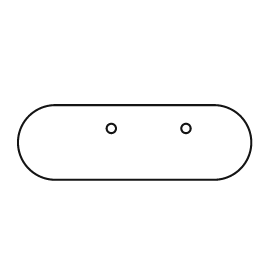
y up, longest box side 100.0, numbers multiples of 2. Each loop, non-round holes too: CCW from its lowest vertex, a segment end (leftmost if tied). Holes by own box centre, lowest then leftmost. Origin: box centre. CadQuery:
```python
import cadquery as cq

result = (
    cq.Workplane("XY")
    .moveTo(-34.0, -16.0)
    .lineTo(34.0, -16.0)
    .threePointArc((50.0, 0.0), (34.0, 16.0))
    .lineTo(-34.0, 16.0)
    .threePointArc((-50.0, 0.0), (-34.0, -16.0))
    .close()
    .moveTo(-10.0, 6.0)
    .circle(2.0)
    .moveTo(22.0, 6.0)
    .circle(2.0)
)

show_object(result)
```